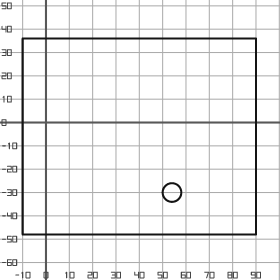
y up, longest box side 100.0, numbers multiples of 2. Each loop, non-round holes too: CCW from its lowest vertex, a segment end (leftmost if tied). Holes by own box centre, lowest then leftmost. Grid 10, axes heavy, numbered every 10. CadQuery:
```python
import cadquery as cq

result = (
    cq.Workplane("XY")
    .moveTo(-10.0, -48.0)
    .lineTo(90.0, -48.0)
    .lineTo(90.0, 36.0)
    .lineTo(-10.0, 36.0)
    .close()
    .moveTo(54.0, -30.0)
    .circle(4.0)
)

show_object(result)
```